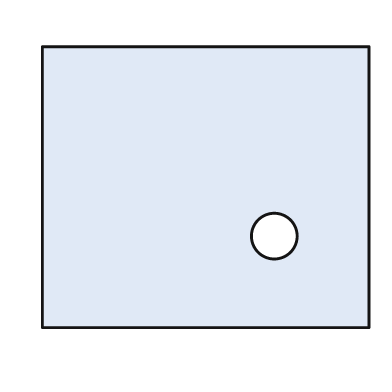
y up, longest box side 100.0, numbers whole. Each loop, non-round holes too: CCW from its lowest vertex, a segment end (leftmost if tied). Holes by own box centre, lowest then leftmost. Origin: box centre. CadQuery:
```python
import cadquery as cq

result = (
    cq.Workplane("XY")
    .moveTo(-50.0, -43.0)
    .lineTo(50.0, -43.0)
    .lineTo(50.0, 43.0)
    .lineTo(-50.0, 43.0)
    .close()
    .moveTo(21.0, -15.0)
    .circle(7.0)
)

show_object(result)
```